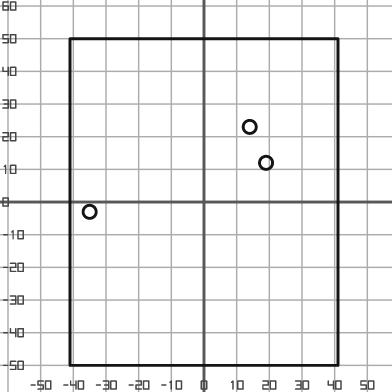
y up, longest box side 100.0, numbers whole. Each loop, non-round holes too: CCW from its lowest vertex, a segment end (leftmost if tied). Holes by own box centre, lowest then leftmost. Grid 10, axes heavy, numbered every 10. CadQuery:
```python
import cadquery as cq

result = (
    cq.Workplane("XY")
    .moveTo(-41.0, -50.0)
    .lineTo(41.0, -50.0)
    .lineTo(41.0, 50.0)
    .lineTo(-41.0, 50.0)
    .close()
    .moveTo(-35.0, -3.0)
    .circle(2.0)
    .moveTo(19.0, 12.0)
    .circle(2.0)
    .moveTo(14.0, 23.0)
    .circle(2.0)
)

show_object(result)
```